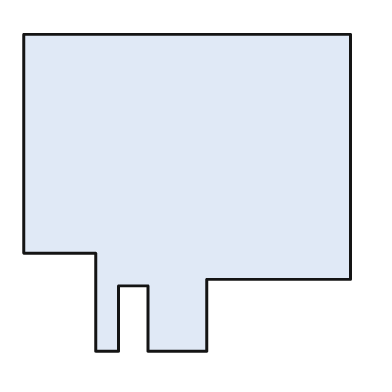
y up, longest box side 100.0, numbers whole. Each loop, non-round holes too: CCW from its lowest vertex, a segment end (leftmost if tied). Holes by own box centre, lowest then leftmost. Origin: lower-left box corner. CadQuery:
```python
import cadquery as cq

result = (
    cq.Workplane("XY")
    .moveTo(22.0, 0.0)
    .lineTo(29.0, 0.0)
    .lineTo(29.0, 20.0)
    .lineTo(38.0, 20.0)
    .lineTo(38.0, 0.0)
    .lineTo(56.0, 0.0)
    .lineTo(56.0, 22.0)
    .lineTo(100.0, 22.0)
    .lineTo(100.0, 97.0)
    .lineTo(0.0, 97.0)
    .lineTo(0.0, 30.0)
    .lineTo(22.0, 30.0)
    .close()
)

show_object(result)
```